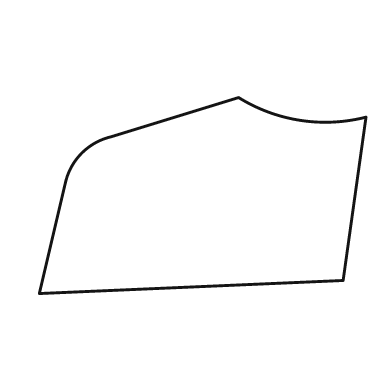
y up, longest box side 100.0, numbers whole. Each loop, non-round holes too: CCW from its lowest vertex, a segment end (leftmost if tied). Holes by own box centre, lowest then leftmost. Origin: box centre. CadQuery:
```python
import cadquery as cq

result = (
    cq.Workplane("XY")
    .moveTo(-50.0, -30.0)
    .lineTo(43.0, -26.0)
    .lineTo(50.0, 24.0)
    .threePointArc((30.0, 23.0), (11.0, 30.0))
    .lineTo(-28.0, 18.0)
    .threePointArc((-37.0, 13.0), (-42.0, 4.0))
    .close()
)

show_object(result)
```